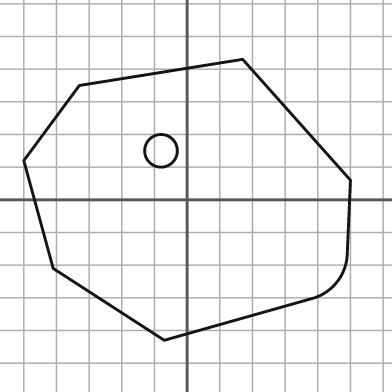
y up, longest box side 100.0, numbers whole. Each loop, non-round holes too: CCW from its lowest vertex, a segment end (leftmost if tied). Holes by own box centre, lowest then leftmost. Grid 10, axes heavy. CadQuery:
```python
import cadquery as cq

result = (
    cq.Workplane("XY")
    .moveTo(-7.0, -43.0)
    .lineTo(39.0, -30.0)
    .threePointArc((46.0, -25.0), (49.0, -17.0))
    .lineTo(50.0, 6.0)
    .lineTo(17.0, 43.0)
    .lineTo(-33.0, 35.0)
    .lineTo(-50.0, 12.0)
    .lineTo(-41.0, -21.0)
    .close()
    .moveTo(-8.0, 15.0)
    .circle(5.0)
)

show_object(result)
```